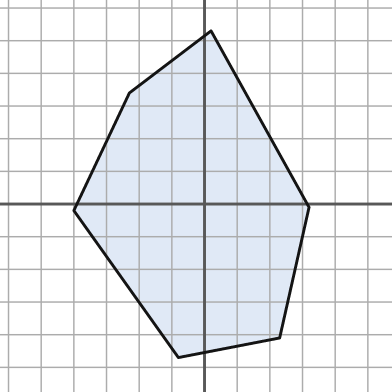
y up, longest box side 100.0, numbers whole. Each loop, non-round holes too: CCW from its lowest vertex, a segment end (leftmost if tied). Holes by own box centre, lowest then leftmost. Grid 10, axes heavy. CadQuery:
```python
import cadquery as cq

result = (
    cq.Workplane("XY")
    .moveTo(-8.0, -47.0)
    .lineTo(23.0, -41.0)
    .lineTo(32.0, -1.0)
    .lineTo(2.0, 53.0)
    .lineTo(-23.0, 34.0)
    .lineTo(-40.0, -2.0)
    .close()
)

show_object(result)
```